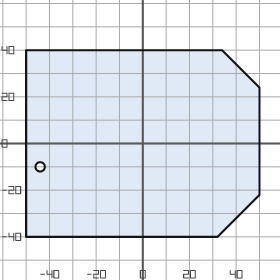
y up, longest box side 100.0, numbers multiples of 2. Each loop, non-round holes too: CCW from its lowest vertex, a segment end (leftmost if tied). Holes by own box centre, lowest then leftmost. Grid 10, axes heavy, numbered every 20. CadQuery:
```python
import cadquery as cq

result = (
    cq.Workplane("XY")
    .moveTo(-50.0, -40.0)
    .lineTo(32.0, -40.0)
    .lineTo(50.0, -22.0)
    .lineTo(50.0, 24.0)
    .lineTo(34.0, 40.0)
    .lineTo(-50.0, 40.0)
    .close()
    .moveTo(-44.0, -10.0)
    .circle(2.0)
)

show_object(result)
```